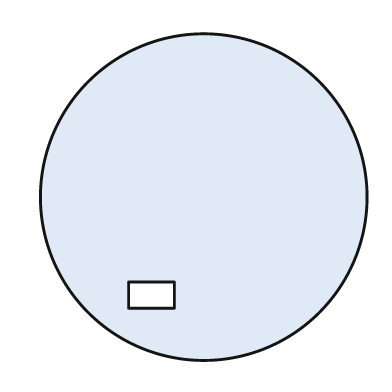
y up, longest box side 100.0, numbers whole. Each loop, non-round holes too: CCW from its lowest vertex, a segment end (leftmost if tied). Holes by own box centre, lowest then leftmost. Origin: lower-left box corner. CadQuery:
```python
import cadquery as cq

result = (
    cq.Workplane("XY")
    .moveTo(50.0, 50.0)
    .circle(50.0)
    .moveTo(27.0, 16.0)
    .lineTo(41.0, 16.0)
    .lineTo(41.0, 24.0)
    .lineTo(27.0, 24.0)
    .close()
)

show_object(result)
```